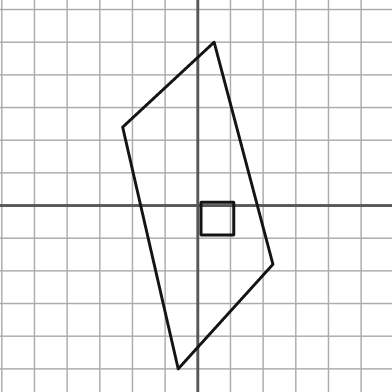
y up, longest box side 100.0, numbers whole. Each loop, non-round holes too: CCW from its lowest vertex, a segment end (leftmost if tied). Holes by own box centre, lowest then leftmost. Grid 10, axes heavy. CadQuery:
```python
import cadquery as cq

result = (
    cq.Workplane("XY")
    .moveTo(-6.0, -50.0)
    .lineTo(23.0, -18.0)
    .lineTo(5.0, 50.0)
    .lineTo(-23.0, 24.0)
    .close()
    .moveTo(1.0, -9.0)
    .lineTo(11.0, -9.0)
    .lineTo(11.0, 1.0)
    .lineTo(1.0, 1.0)
    .close()
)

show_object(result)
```